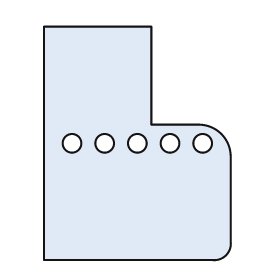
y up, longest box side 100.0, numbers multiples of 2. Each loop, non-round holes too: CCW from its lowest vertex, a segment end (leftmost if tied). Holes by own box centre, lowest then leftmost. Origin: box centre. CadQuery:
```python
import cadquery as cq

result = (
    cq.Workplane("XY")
    .moveTo(-40.0, -50.0)
    .lineTo(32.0, -50.0)
    .threePointArc((38.0, -48.0), (40.0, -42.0))
    .lineTo(40.0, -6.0)
    .threePointArc((36.0, 4.0), (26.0, 8.0))
    .lineTo(6.0, 8.0)
    .lineTo(6.0, 50.0)
    .lineTo(-40.0, 50.0)
    .close()
    .moveTo(-28.0, 0.0)
    .circle(4.0)
    .moveTo(-14.0, 0.0)
    .circle(4.0)
    .moveTo(0.0, 0.0)
    .circle(4.0)
    .moveTo(14.0, 0.0)
    .circle(4.0)
    .moveTo(28.0, 0.0)
    .circle(4.0)
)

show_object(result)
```